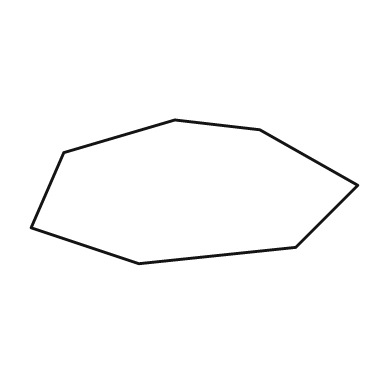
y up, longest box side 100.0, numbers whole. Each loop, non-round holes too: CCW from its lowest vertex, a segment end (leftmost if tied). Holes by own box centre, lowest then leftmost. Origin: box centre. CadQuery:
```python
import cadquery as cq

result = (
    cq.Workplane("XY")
    .moveTo(-17.0, -22.0)
    .lineTo(31.0, -17.0)
    .lineTo(50.0, 2.0)
    .lineTo(20.0, 19.0)
    .lineTo(-6.0, 22.0)
    .lineTo(-40.0, 12.0)
    .lineTo(-50.0, -11.0)
    .close()
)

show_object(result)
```